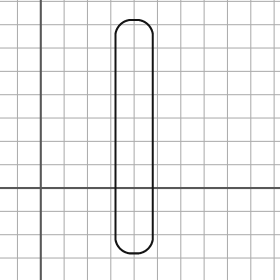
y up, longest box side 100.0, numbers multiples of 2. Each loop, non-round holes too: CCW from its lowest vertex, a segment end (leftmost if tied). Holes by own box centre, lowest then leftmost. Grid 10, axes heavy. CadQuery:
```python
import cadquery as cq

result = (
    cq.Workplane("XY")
    .moveTo(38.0, -28.0)
    .lineTo(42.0, -28.0)
    .threePointArc((46.0, -26.0), (48.0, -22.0))
    .lineTo(48.0, 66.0)
    .threePointArc((46.0, 70.0), (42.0, 72.0))
    .lineTo(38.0, 72.0)
    .threePointArc((34.0, 70.0), (32.0, 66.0))
    .lineTo(32.0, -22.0)
    .threePointArc((34.0, -26.0), (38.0, -28.0))
    .close()
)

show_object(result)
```